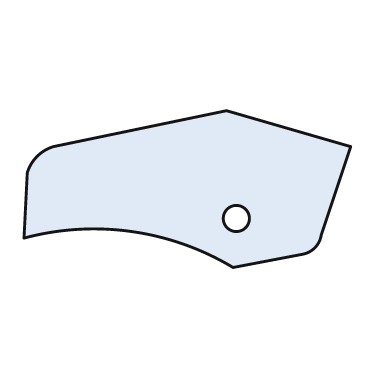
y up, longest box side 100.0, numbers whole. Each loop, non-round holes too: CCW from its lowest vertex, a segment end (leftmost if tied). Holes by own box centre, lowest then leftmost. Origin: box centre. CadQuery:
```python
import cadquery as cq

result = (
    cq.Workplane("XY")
    .moveTo(14.0, -24.0)
    .lineTo(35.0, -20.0)
    .threePointArc((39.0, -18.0), (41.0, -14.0))
    .lineTo(50.0, 13.0)
    .lineTo(12.0, 24.0)
    .lineTo(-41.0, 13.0)
    .threePointArc((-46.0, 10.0), (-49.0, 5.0))
    .lineTo(-50.0, -15.0)
    .threePointArc((-17.0, -13.0), (14.0, -24.0))
    .close()
    .moveTo(15.0, -9.0)
    .circle(4.0)
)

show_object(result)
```